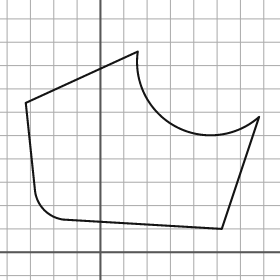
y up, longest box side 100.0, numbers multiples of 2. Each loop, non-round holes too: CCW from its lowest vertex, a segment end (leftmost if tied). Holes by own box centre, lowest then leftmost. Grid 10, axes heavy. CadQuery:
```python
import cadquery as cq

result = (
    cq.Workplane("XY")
    .moveTo(52.0, 10.0)
    .lineTo(68.0, 58.0)
    .threePointArc((32.0, 54.0), (16.0, 86.0))
    .lineTo(-32.0, 64.0)
    .lineTo(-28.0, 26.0)
    .threePointArc((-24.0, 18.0), (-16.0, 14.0))
    .close()
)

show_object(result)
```